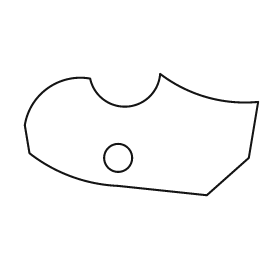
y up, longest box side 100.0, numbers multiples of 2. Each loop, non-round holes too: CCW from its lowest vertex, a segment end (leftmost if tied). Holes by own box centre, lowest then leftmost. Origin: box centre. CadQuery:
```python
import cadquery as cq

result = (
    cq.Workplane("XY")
    .moveTo(28.0, -26.0)
    .lineTo(46.0, -10.0)
    .lineTo(50.0, 14.0)
    .threePointArc((28.0, 16.0), (8.0, 26.0))
    .threePointArc((-6.0, 12.0), (-22.0, 24.0))
    .threePointArc((-40.0, 20.0), (-50.0, 4.0))
    .lineTo(-48.0, -8.0)
    .threePointArc((-30.0, -18.0), (-10.0, -22.0))
    .close()
    .moveTo(-10.0, -10.0)
    .circle(6.0)
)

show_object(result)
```